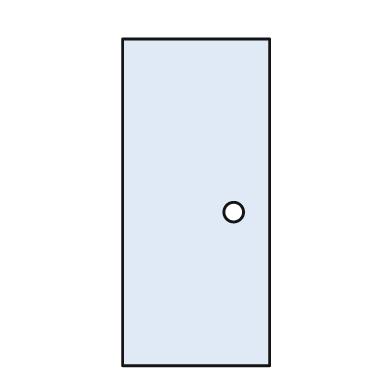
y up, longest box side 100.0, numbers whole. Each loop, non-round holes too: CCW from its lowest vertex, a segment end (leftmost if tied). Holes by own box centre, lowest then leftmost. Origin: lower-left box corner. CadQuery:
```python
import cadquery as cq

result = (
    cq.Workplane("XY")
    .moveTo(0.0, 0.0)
    .lineTo(45.0, 0.0)
    .lineTo(45.0, 100.0)
    .lineTo(0.0, 100.0)
    .close()
    .moveTo(34.0, 47.0)
    .circle(3.0)
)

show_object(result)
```